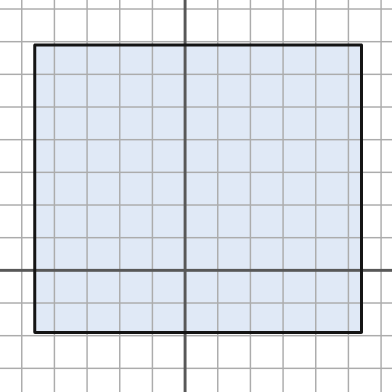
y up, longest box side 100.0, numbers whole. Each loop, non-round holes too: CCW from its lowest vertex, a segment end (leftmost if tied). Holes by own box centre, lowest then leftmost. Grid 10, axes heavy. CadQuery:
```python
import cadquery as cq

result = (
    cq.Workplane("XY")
    .moveTo(-46.0, -19.0)
    .lineTo(54.0, -19.0)
    .lineTo(54.0, 69.0)
    .lineTo(-46.0, 69.0)
    .close()
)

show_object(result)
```